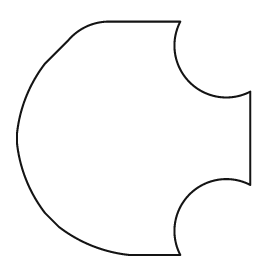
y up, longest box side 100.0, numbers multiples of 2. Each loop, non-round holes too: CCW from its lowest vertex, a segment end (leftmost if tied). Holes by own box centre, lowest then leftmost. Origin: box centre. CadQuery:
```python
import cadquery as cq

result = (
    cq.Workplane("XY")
    .moveTo(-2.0, -50.0)
    .lineTo(20.0, -50.0)
    .threePointArc((24.0, -24.0), (50.0, -20.0))
    .lineTo(50.0, 20.0)
    .threePointArc((24.0, 24.0), (20.0, 50.0))
    .lineTo(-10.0, 50.0)
    .threePointArc((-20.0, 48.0), (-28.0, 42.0))
    .lineTo(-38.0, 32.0)
    .threePointArc((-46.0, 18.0), (-50.0, 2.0))
    .lineTo(-50.0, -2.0)
    .threePointArc((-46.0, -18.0), (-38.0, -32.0))
    .lineTo(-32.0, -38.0)
    .threePointArc((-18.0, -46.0), (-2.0, -50.0))
    .close()
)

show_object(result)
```